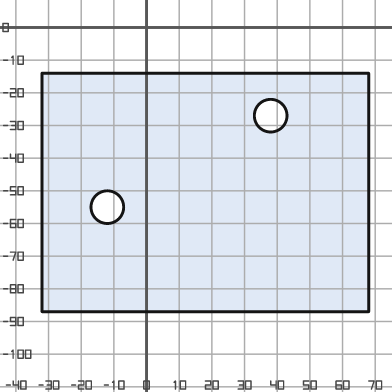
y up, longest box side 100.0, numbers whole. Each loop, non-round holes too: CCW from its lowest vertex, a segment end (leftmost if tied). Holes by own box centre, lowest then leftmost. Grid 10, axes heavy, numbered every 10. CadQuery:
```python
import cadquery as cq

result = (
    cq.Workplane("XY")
    .moveTo(-32.0, -87.0)
    .lineTo(68.0, -87.0)
    .lineTo(68.0, -14.0)
    .lineTo(-32.0, -14.0)
    .close()
    .moveTo(-12.0, -55.0)
    .circle(5.0)
    .moveTo(38.0, -27.0)
    .circle(5.0)
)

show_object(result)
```